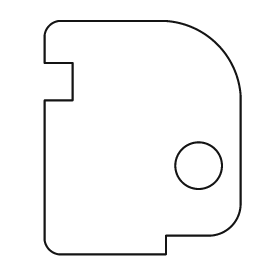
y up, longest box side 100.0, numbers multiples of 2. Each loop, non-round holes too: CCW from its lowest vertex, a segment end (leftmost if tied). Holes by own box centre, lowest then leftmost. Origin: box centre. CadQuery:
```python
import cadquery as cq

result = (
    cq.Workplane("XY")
    .moveTo(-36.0, -50.0)
    .lineTo(10.0, -50.0)
    .lineTo(10.0, -42.0)
    .lineTo(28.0, -42.0)
    .threePointArc((38.0, -38.0), (42.0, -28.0))
    .lineTo(42.0, 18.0)
    .threePointArc((32.0, 40.0), (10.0, 50.0))
    .lineTo(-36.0, 50.0)
    .threePointArc((-40.0, 48.0), (-42.0, 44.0))
    .lineTo(-42.0, 32.0)
    .lineTo(-30.0, 32.0)
    .lineTo(-30.0, 16.0)
    .lineTo(-42.0, 16.0)
    .lineTo(-42.0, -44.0)
    .threePointArc((-40.0, -48.0), (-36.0, -50.0))
    .close()
    .moveTo(24.0, -12.0)
    .circle(10.0)
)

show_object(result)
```